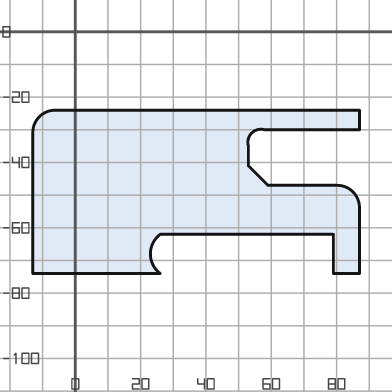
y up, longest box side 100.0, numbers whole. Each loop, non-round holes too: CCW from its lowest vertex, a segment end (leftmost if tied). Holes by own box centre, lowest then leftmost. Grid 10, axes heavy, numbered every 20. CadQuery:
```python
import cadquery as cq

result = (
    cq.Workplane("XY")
    .moveTo(-13.0, -74.0)
    .lineTo(26.0, -74.0)
    .threePointArc((23.0, -68.0), (26.0, -62.0))
    .lineTo(79.0, -62.0)
    .lineTo(79.0, -74.0)
    .lineTo(87.0, -74.0)
    .lineTo(87.0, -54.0)
    .threePointArc((85.0, -49.0), (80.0, -47.0))
    .lineTo(59.0, -47.0)
    .lineTo(53.0, -41.0)
    .lineTo(53.0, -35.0)
    .threePointArc((54.0, -31.0), (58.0, -30.0))
    .lineTo(87.0, -30.0)
    .lineTo(87.0, -24.0)
    .lineTo(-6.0, -24.0)
    .threePointArc((-11.0, -26.0), (-13.0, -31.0))
    .close()
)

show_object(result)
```